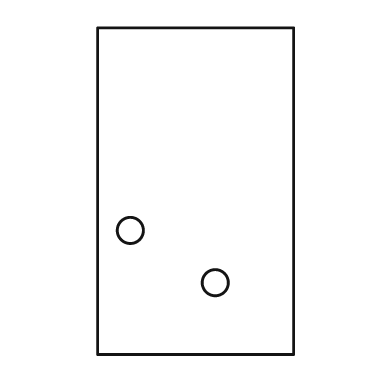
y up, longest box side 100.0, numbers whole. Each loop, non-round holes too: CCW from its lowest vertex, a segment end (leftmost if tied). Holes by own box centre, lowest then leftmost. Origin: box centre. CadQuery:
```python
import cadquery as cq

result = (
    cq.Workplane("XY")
    .moveTo(-30.0, -50.0)
    .lineTo(30.0, -50.0)
    .lineTo(30.0, 50.0)
    .lineTo(-30.0, 50.0)
    .close()
    .moveTo(6.0, -28.0)
    .circle(4.0)
    .moveTo(-20.0, -12.0)
    .circle(4.0)
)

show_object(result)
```